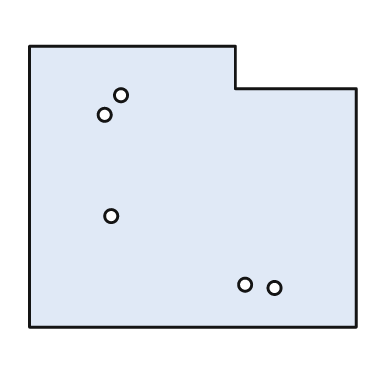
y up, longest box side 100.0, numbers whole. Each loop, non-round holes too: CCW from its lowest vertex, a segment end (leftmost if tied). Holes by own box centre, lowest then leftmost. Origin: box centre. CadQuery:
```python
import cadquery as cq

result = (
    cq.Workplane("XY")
    .moveTo(-50.0, -43.0)
    .lineTo(50.0, -43.0)
    .lineTo(50.0, 30.0)
    .lineTo(13.0, 30.0)
    .lineTo(13.0, 43.0)
    .lineTo(-50.0, 43.0)
    .close()
    .moveTo(25.0, -31.0)
    .circle(2.0)
    .moveTo(16.0, -30.0)
    .circle(2.0)
    .moveTo(-25.0, -9.0)
    .circle(2.0)
    .moveTo(-27.0, 22.0)
    .circle(2.0)
    .moveTo(-22.0, 28.0)
    .circle(2.0)
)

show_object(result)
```